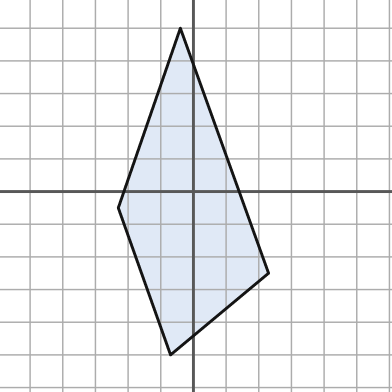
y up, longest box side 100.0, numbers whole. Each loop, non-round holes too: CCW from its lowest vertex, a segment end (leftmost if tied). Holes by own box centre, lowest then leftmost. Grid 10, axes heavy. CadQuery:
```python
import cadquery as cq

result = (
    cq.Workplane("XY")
    .moveTo(-7.0, -50.0)
    .lineTo(23.0, -25.0)
    .lineTo(-4.0, 50.0)
    .lineTo(-23.0, -5.0)
    .close()
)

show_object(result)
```